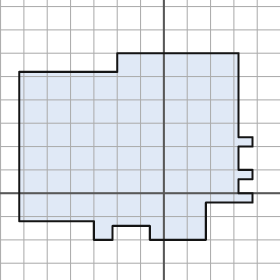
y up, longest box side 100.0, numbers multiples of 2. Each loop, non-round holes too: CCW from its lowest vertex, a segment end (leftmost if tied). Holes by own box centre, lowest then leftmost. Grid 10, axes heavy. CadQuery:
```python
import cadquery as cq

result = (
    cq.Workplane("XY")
    .moveTo(-30.0, -20.0)
    .lineTo(-22.0, -20.0)
    .lineTo(-22.0, -14.0)
    .lineTo(-6.0, -14.0)
    .lineTo(-6.0, -20.0)
    .lineTo(18.0, -20.0)
    .lineTo(18.0, -4.0)
    .lineTo(38.0, -4.0)
    .lineTo(38.0, 0.0)
    .lineTo(32.0, 0.0)
    .lineTo(32.0, 6.0)
    .lineTo(38.0, 6.0)
    .lineTo(38.0, 10.0)
    .lineTo(32.0, 10.0)
    .lineTo(32.0, 20.0)
    .lineTo(38.0, 20.0)
    .lineTo(38.0, 24.0)
    .lineTo(32.0, 24.0)
    .lineTo(32.0, 60.0)
    .lineTo(-20.0, 60.0)
    .lineTo(-20.0, 52.0)
    .lineTo(-62.0, 52.0)
    .lineTo(-62.0, -12.0)
    .lineTo(-30.0, -12.0)
    .close()
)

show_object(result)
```